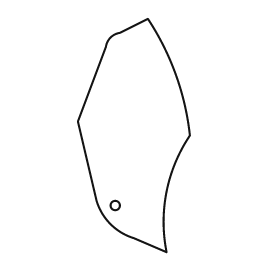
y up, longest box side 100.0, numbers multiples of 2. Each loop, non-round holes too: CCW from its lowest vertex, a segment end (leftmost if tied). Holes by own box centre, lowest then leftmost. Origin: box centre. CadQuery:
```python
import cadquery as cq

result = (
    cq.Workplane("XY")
    .moveTo(14.0, -50.0)
    .threePointArc((14.0, -24.0), (24.0, 0.0))
    .threePointArc((18.0, 26.0), (6.0, 50.0))
    .lineTo(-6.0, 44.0)
    .threePointArc((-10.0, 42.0), (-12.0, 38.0))
    .lineTo(-24.0, 6.0)
    .lineTo(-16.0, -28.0)
    .threePointArc((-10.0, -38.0), (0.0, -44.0))
    .close()
    .moveTo(-8.0, -30.0)
    .circle(2.0)
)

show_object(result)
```